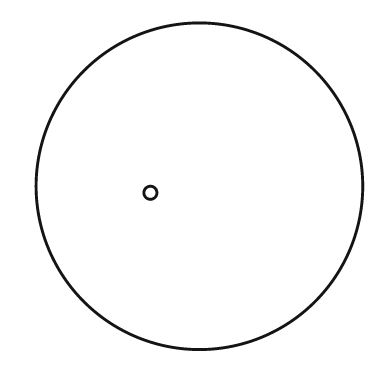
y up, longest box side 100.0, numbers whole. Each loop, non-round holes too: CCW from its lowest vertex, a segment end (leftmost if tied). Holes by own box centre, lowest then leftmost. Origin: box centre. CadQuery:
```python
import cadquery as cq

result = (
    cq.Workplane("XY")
    .moveTo(0.0, 0.0)
    .circle(50.0)
    .moveTo(-15.0, -2.0)
    .circle(2.0)
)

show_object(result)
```